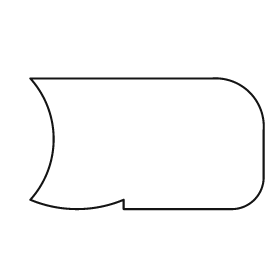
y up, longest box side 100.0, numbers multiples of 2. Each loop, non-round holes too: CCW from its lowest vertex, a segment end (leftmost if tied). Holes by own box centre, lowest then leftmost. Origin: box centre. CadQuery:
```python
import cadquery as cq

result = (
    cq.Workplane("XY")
    .moveTo(-10.0, -28.0)
    .lineTo(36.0, -28.0)
    .threePointArc((46.0, -24.0), (50.0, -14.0))
    .lineTo(50.0, 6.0)
    .threePointArc((44.0, 22.0), (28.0, 28.0))
    .lineTo(-50.0, 28.0)
    .threePointArc((-40.0, 2.0), (-50.0, -24.0))
    .threePointArc((-30.0, -28.0), (-10.0, -24.0))
    .close()
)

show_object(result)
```